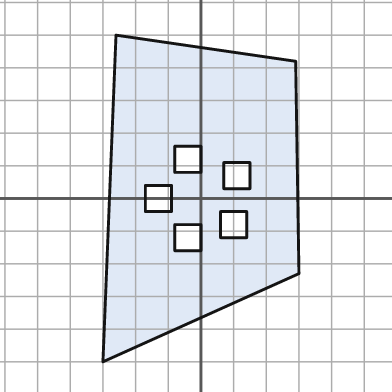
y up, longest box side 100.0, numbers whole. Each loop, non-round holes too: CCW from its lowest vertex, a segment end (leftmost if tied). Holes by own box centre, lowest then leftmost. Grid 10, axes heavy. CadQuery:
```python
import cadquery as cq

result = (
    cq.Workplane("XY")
    .moveTo(-30.0, -50.0)
    .lineTo(30.0, -23.0)
    .lineTo(29.0, 42.0)
    .lineTo(-26.0, 50.0)
    .close()
    .moveTo(-8.0, -16.0)
    .lineTo(0.0, -16.0)
    .lineTo(0.0, -8.0)
    .lineTo(-8.0, -8.0)
    .close()
    .moveTo(6.0, -12.0)
    .lineTo(14.0, -12.0)
    .lineTo(14.0, -4.0)
    .lineTo(6.0, -4.0)
    .close()
    .moveTo(-17.0, -4.0)
    .lineTo(-9.0, -4.0)
    .lineTo(-9.0, 4.0)
    .lineTo(-17.0, 4.0)
    .close()
    .moveTo(7.0, 3.0)
    .lineTo(15.0, 3.0)
    .lineTo(15.0, 11.0)
    .lineTo(7.0, 11.0)
    .close()
    .moveTo(-8.0, 8.0)
    .lineTo(0.0, 8.0)
    .lineTo(0.0, 16.0)
    .lineTo(-8.0, 16.0)
    .close()
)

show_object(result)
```